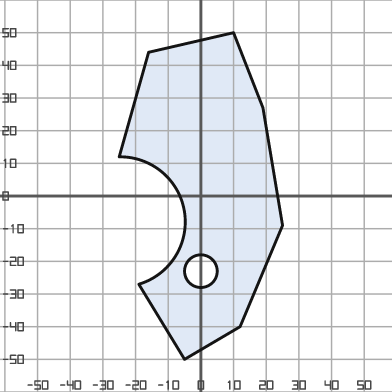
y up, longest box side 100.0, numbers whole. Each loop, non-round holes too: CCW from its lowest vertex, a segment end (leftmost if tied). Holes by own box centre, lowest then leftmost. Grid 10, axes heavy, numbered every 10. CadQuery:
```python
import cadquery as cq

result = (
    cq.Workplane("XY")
    .moveTo(-5.0, -50.0)
    .lineTo(12.0, -40.0)
    .lineTo(25.0, -9.0)
    .lineTo(19.0, 27.0)
    .lineTo(10.0, 50.0)
    .lineTo(-16.0, 44.0)
    .lineTo(-25.0, 12.0)
    .threePointArc((-5.0, -5.0), (-19.0, -27.0))
    .close()
    .moveTo(0.0, -23.0)
    .circle(5.0)
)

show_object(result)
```